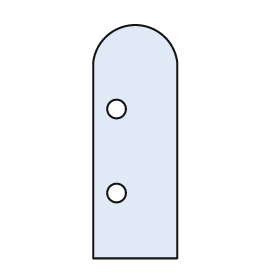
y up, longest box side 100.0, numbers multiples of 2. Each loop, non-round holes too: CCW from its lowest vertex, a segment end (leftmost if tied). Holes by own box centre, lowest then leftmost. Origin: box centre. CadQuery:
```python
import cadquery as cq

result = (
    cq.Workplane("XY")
    .moveTo(-18.0, -50.0)
    .lineTo(18.0, -50.0)
    .lineTo(18.0, 34.0)
    .threePointArc((0.0, 50.0), (-18.0, 34.0))
    .close()
    .moveTo(-8.0, -22.0)
    .circle(4.0)
    .moveTo(-8.0, 14.0)
    .circle(4.0)
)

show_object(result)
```